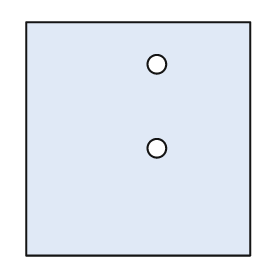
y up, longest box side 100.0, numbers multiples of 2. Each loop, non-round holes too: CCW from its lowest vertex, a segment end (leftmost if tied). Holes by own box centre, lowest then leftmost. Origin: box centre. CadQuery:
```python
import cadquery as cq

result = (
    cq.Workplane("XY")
    .moveTo(-48.0, -50.0)
    .lineTo(48.0, -50.0)
    .lineTo(48.0, 50.0)
    .lineTo(-48.0, 50.0)
    .close()
    .moveTo(8.0, -4.0)
    .circle(4.0)
    .moveTo(8.0, 32.0)
    .circle(4.0)
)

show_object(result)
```